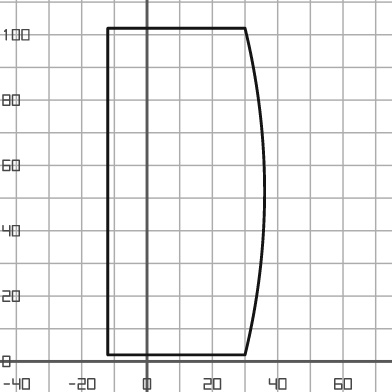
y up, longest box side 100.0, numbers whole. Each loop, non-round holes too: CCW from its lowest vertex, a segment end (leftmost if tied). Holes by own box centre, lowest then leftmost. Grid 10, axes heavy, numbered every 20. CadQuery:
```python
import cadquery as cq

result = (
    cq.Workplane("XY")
    .moveTo(-12.0, 2.0)
    .lineTo(30.0, 2.0)
    .threePointArc((36.0, 52.0), (30.0, 102.0))
    .lineTo(-12.0, 102.0)
    .close()
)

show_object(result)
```